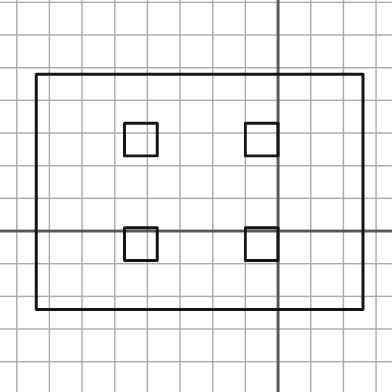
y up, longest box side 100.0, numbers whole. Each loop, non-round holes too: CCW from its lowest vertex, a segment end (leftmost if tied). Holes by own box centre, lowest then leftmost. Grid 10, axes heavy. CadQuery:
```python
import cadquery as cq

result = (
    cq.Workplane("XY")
    .moveTo(-74.0, -24.0)
    .lineTo(26.0, -24.0)
    .lineTo(26.0, 48.0)
    .lineTo(-74.0, 48.0)
    .close()
    .moveTo(-47.0, -9.0)
    .lineTo(-37.0, -9.0)
    .lineTo(-37.0, 1.0)
    .lineTo(-47.0, 1.0)
    .close()
    .moveTo(-10.0, -9.0)
    .lineTo(0.0, -9.0)
    .lineTo(0.0, 1.0)
    .lineTo(-10.0, 1.0)
    .close()
    .moveTo(-47.0, 23.0)
    .lineTo(-37.0, 23.0)
    .lineTo(-37.0, 33.0)
    .lineTo(-47.0, 33.0)
    .close()
    .moveTo(-10.0, 23.0)
    .lineTo(0.0, 23.0)
    .lineTo(0.0, 33.0)
    .lineTo(-10.0, 33.0)
    .close()
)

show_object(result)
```